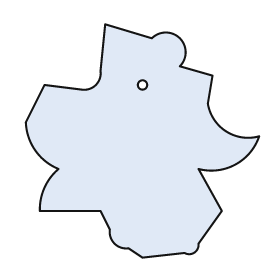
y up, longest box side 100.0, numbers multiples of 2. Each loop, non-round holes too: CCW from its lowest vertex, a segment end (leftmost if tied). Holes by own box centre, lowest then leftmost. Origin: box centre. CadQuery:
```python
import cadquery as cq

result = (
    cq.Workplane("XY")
    .moveTo(0.0, -50.0)
    .lineTo(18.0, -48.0)
    .threePointArc((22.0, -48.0), (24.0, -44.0))
    .lineTo(34.0, -30.0)
    .lineTo(24.0, -12.0)
    .threePointArc((40.0, -10.0), (50.0, 2.0))
    .threePointArc((36.0, 4.0), (28.0, 16.0))
    .lineTo(30.0, 28.0)
    .lineTo(16.0, 32.0)
    .threePointArc((16.0, 44.0), (4.0, 44.0))
    .lineTo(-16.0, 50.0)
    .lineTo(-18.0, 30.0)
    .threePointArc((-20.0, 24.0), (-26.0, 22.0))
    .lineTo(-42.0, 24.0)
    .lineTo(-50.0, 8.0)
    .threePointArc((-46.0, -4.0), (-36.0, -12.0))
    .threePointArc((-42.0, -20.0), (-44.0, -30.0))
    .lineTo(-18.0, -30.0)
    .lineTo(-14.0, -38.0)
    .threePointArc((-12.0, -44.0), (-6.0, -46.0))
    .close()
    .moveTo(0.0, 24.0)
    .circle(2.0)
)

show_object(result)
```